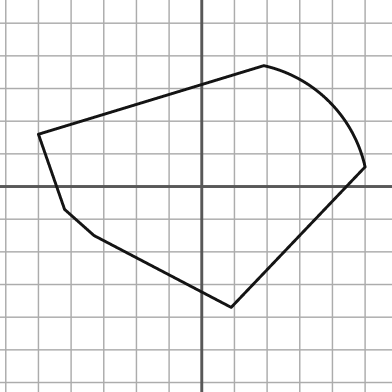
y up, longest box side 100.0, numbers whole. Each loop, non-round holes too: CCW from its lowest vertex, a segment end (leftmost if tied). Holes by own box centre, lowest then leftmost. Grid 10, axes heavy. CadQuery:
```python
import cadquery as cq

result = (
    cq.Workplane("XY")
    .moveTo(9.0, -37.0)
    .lineTo(50.0, 6.0)
    .threePointArc((39.0, 26.0), (19.0, 37.0))
    .lineTo(-50.0, 16.0)
    .lineTo(-42.0, -7.0)
    .lineTo(-33.0, -15.0)
    .close()
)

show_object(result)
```